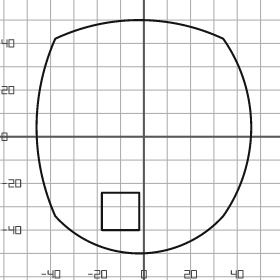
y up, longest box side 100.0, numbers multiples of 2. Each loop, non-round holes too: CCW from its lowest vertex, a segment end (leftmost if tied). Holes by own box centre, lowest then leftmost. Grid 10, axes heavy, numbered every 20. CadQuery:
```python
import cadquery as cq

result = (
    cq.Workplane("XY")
    .moveTo(-38.0, -34.0)
    .threePointArc((-2.0, -50.0), (34.0, -34.0))
    .threePointArc((46.0, 4.0), (34.0, 42.0))
    .threePointArc((-2.0, 50.0), (-38.0, 42.0))
    .threePointArc((-46.0, 4.0), (-38.0, -34.0))
    .close()
    .moveTo(-18.0, -40.0)
    .lineTo(-2.0, -40.0)
    .lineTo(-2.0, -24.0)
    .lineTo(-18.0, -24.0)
    .close()
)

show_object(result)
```